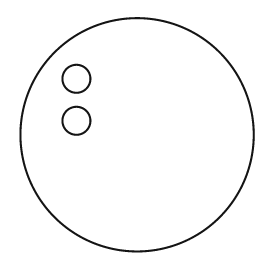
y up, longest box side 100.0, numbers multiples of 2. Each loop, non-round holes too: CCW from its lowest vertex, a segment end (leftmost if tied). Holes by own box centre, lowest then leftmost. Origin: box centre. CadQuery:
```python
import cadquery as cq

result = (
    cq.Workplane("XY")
    .moveTo(0.0, 0.0)
    .circle(50.0)
    .moveTo(-26.0, 6.0)
    .circle(6.0)
    .moveTo(-26.0, 24.0)
    .circle(6.0)
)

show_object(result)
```